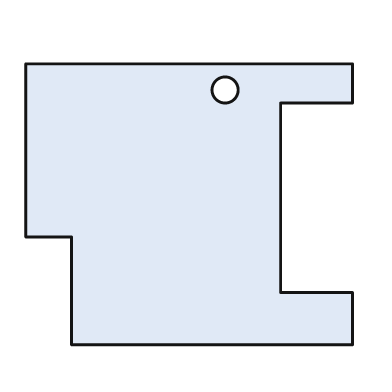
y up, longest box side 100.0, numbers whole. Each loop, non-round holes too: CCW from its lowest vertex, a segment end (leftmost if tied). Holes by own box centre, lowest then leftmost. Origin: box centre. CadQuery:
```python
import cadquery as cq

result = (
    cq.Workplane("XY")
    .moveTo(-36.0, -43.0)
    .lineTo(50.0, -43.0)
    .lineTo(50.0, -27.0)
    .lineTo(28.0, -27.0)
    .lineTo(28.0, 31.0)
    .lineTo(50.0, 31.0)
    .lineTo(50.0, 43.0)
    .lineTo(-50.0, 43.0)
    .lineTo(-50.0, -10.0)
    .lineTo(-36.0, -10.0)
    .close()
    .moveTo(11.0, 35.0)
    .circle(4.0)
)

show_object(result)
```